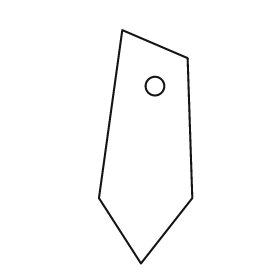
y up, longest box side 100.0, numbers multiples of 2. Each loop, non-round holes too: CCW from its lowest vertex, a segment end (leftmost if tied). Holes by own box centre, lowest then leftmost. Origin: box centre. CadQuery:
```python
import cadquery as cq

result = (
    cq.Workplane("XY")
    .moveTo(-2.0, -50.0)
    .lineTo(20.0, -22.0)
    .lineTo(18.0, 38.0)
    .lineTo(-10.0, 50.0)
    .lineTo(-20.0, -22.0)
    .close()
    .moveTo(4.0, 26.0)
    .circle(4.0)
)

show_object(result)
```